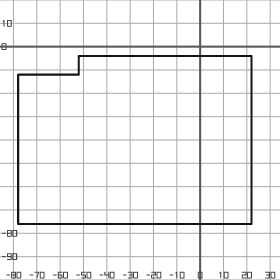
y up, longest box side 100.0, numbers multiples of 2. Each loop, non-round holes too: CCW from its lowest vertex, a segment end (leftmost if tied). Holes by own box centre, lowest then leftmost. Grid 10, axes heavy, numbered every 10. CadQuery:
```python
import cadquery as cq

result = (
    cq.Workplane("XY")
    .moveTo(-78.0, -76.0)
    .lineTo(22.0, -76.0)
    .lineTo(22.0, -4.0)
    .lineTo(-52.0, -4.0)
    .lineTo(-52.0, -12.0)
    .lineTo(-78.0, -12.0)
    .close()
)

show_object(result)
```